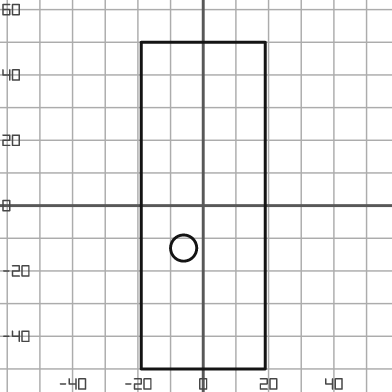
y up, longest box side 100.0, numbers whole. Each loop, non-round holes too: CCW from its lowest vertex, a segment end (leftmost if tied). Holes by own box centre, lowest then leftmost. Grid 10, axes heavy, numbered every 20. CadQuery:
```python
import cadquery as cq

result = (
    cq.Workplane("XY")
    .moveTo(-19.0, -50.0)
    .lineTo(19.0, -50.0)
    .lineTo(19.0, 50.0)
    .lineTo(-19.0, 50.0)
    .close()
    .moveTo(-6.0, -13.0)
    .circle(4.0)
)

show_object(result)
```